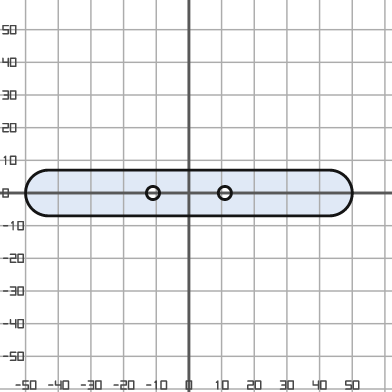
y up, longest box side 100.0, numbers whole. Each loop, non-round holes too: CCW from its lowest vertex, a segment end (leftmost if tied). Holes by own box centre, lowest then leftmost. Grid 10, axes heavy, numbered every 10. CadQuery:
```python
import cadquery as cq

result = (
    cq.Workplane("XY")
    .moveTo(-43.0, -7.0)
    .lineTo(43.0, -7.0)
    .threePointArc((50.0, 0.0), (43.0, 7.0))
    .lineTo(-43.0, 7.0)
    .threePointArc((-50.0, 0.0), (-43.0, -7.0))
    .close()
    .moveTo(-11.0, 0.0)
    .circle(2.0)
    .moveTo(11.0, 0.0)
    .circle(2.0)
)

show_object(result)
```